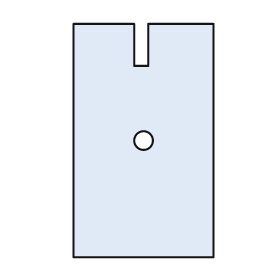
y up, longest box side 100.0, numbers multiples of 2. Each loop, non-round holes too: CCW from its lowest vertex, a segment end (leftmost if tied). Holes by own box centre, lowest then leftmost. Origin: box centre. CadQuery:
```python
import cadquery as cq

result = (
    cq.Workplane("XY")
    .moveTo(-30.0, -50.0)
    .lineTo(30.0, -50.0)
    .lineTo(30.0, 50.0)
    .lineTo(2.0, 50.0)
    .lineTo(2.0, 32.0)
    .lineTo(-4.0, 32.0)
    .lineTo(-4.0, 50.0)
    .lineTo(-30.0, 50.0)
    .close()
    .moveTo(0.0, 0.0)
    .circle(4.0)
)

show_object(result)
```